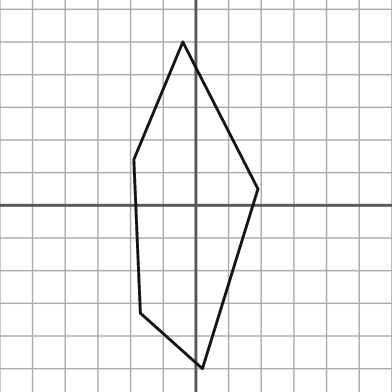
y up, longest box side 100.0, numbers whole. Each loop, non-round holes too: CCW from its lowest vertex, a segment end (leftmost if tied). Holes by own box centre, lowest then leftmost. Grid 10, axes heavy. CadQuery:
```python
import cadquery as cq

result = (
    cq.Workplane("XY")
    .moveTo(2.0, -50.0)
    .lineTo(19.0, 5.0)
    .lineTo(-4.0, 50.0)
    .lineTo(-19.0, 14.0)
    .lineTo(-17.0, -33.0)
    .close()
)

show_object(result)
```